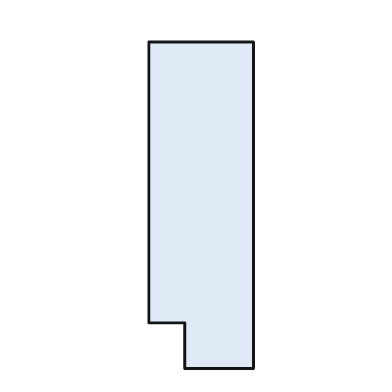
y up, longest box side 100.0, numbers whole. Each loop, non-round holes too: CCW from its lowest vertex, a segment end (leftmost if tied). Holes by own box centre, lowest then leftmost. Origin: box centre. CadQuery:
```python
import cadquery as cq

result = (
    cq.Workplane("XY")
    .moveTo(-5.0, -50.0)
    .lineTo(16.0, -50.0)
    .lineTo(16.0, 50.0)
    .lineTo(-16.0, 50.0)
    .lineTo(-16.0, -36.0)
    .lineTo(-5.0, -36.0)
    .close()
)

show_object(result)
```